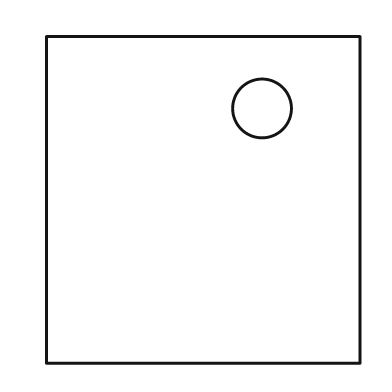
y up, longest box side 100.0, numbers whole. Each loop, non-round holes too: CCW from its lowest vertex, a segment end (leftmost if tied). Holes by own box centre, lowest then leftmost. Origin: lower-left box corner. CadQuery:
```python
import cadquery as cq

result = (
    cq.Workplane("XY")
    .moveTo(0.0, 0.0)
    .lineTo(96.0, 0.0)
    .lineTo(96.0, 100.0)
    .lineTo(0.0, 100.0)
    .close()
    .moveTo(66.0, 78.0)
    .circle(9.0)
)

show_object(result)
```